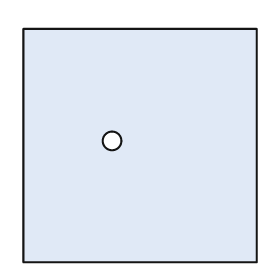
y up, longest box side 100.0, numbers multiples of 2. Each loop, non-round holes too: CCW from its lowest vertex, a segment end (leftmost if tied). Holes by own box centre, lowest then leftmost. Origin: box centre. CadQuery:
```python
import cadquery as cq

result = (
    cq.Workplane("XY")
    .moveTo(-50.0, -50.0)
    .lineTo(50.0, -50.0)
    .lineTo(50.0, 50.0)
    .lineTo(-50.0, 50.0)
    .close()
    .moveTo(-12.0, 2.0)
    .circle(4.0)
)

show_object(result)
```